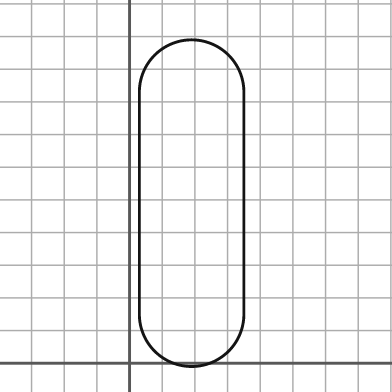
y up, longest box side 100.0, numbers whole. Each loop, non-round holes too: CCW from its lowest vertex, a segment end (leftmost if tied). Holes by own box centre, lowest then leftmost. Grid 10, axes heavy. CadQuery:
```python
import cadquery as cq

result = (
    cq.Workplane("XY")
    .moveTo(3.0, 15.0)
    .threePointArc((19.0, -1.0), (35.0, 15.0))
    .lineTo(35.0, 83.0)
    .threePointArc((19.0, 99.0), (3.0, 83.0))
    .close()
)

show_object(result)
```